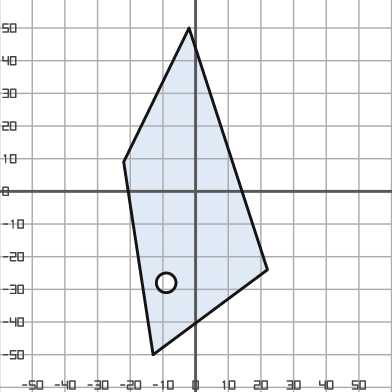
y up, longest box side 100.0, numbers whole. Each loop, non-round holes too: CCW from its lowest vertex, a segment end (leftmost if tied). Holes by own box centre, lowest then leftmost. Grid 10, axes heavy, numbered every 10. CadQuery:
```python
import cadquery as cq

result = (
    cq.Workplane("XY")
    .moveTo(-13.0, -50.0)
    .lineTo(22.0, -24.0)
    .lineTo(-2.0, 50.0)
    .lineTo(-22.0, 9.0)
    .close()
    .moveTo(-9.0, -28.0)
    .circle(3.0)
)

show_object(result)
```